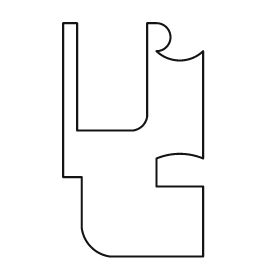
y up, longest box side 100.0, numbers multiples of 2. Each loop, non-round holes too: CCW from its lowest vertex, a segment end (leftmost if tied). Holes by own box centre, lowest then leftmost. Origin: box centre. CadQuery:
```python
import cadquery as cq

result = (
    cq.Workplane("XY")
    .moveTo(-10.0, -50.0)
    .lineTo(30.0, -50.0)
    .lineTo(30.0, -20.0)
    .lineTo(10.0, -20.0)
    .lineTo(10.0, -8.0)
    .threePointArc((20.0, -6.0), (30.0, -8.0))
    .lineTo(30.0, 38.0)
    .threePointArc((20.0, 34.0), (10.0, 38.0))
    .threePointArc((16.0, 44.0), (10.0, 50.0))
    .lineTo(6.0, 50.0)
    .lineTo(6.0, 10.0)
    .threePointArc((4.0, 6.0), (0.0, 4.0))
    .lineTo(-24.0, 4.0)
    .lineTo(-24.0, 50.0)
    .lineTo(-30.0, 50.0)
    .lineTo(-30.0, -16.0)
    .lineTo(-22.0, -16.0)
    .lineTo(-22.0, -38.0)
    .threePointArc((-18.0, -46.0), (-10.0, -50.0))
    .close()
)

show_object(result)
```